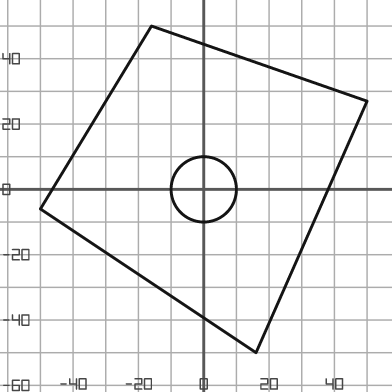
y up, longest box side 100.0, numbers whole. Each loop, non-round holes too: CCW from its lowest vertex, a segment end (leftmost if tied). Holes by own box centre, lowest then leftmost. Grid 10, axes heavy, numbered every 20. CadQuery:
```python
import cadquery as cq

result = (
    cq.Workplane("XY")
    .moveTo(16.0, -50.0)
    .lineTo(50.0, 27.0)
    .lineTo(-16.0, 50.0)
    .lineTo(-50.0, -6.0)
    .close()
    .moveTo(0.0, 0.0)
    .circle(10.0)
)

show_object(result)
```